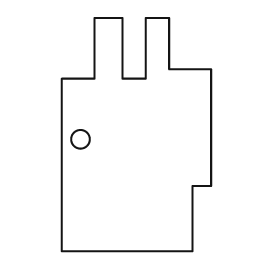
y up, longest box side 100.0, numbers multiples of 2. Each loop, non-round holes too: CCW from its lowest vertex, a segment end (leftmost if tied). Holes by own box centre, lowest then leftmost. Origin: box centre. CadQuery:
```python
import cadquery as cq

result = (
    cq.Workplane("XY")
    .moveTo(-32.0, -50.0)
    .lineTo(24.0, -50.0)
    .lineTo(24.0, -22.0)
    .lineTo(32.0, -22.0)
    .lineTo(32.0, 28.0)
    .lineTo(14.0, 28.0)
    .lineTo(14.0, 50.0)
    .lineTo(4.0, 50.0)
    .lineTo(4.0, 24.0)
    .lineTo(-6.0, 24.0)
    .lineTo(-6.0, 50.0)
    .lineTo(-18.0, 50.0)
    .lineTo(-18.0, 24.0)
    .lineTo(-32.0, 24.0)
    .close()
    .moveTo(-24.0, -2.0)
    .circle(4.0)
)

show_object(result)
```